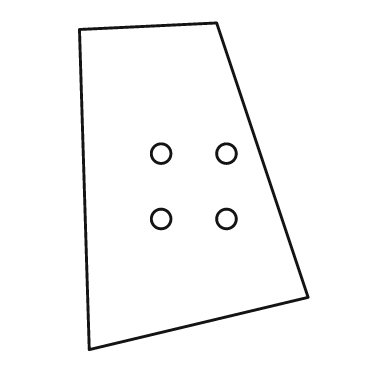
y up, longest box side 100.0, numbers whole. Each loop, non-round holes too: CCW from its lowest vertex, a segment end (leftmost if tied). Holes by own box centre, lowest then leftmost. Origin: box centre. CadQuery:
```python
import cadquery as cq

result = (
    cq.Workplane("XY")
    .moveTo(-32.0, -50.0)
    .lineTo(35.0, -34.0)
    .lineTo(7.0, 50.0)
    .lineTo(-35.0, 48.0)
    .close()
    .moveTo(-10.0, -10.0)
    .circle(3.0)
    .moveTo(10.0, -10.0)
    .circle(3.0)
    .moveTo(-10.0, 10.0)
    .circle(3.0)
    .moveTo(10.0, 10.0)
    .circle(3.0)
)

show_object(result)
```